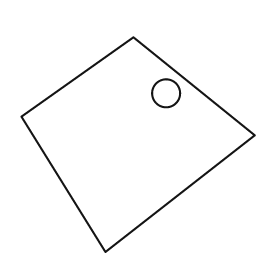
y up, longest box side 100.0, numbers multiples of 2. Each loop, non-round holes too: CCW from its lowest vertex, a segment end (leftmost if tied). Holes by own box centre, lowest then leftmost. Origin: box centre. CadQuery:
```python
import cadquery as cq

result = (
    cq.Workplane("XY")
    .moveTo(-14.0, -46.0)
    .lineTo(50.0, 4.0)
    .lineTo(-2.0, 46.0)
    .lineTo(-50.0, 12.0)
    .close()
    .moveTo(12.0, 22.0)
    .circle(6.0)
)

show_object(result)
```